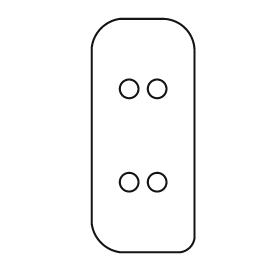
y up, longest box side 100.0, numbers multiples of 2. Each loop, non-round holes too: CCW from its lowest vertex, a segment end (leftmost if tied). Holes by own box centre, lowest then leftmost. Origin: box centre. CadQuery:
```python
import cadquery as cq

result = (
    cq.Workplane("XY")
    .moveTo(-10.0, -50.0)
    .lineTo(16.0, -50.0)
    .threePointArc((20.0, -48.0), (22.0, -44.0))
    .lineTo(22.0, 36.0)
    .threePointArc((18.0, 46.0), (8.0, 50.0))
    .lineTo(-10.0, 50.0)
    .threePointArc((-18.0, 46.0), (-22.0, 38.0))
    .lineTo(-22.0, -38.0)
    .threePointArc((-18.0, -46.0), (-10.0, -50.0))
    .close()
    .moveTo(-6.0, -20.0)
    .circle(4.0)
    .moveTo(6.0, -20.0)
    .circle(4.0)
    .moveTo(-6.0, 20.0)
    .circle(4.0)
    .moveTo(6.0, 20.0)
    .circle(4.0)
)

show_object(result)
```